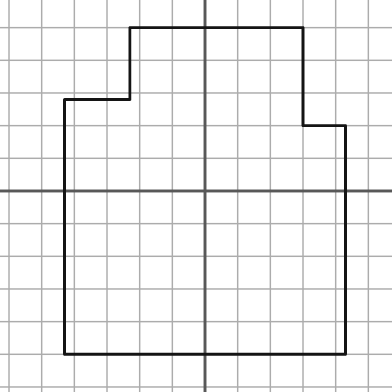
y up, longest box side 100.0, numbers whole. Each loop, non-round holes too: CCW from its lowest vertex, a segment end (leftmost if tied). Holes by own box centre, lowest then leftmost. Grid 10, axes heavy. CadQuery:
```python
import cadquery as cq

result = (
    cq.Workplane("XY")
    .moveTo(-43.0, -50.0)
    .lineTo(43.0, -50.0)
    .lineTo(43.0, 20.0)
    .lineTo(30.0, 20.0)
    .lineTo(30.0, 50.0)
    .lineTo(-23.0, 50.0)
    .lineTo(-23.0, 28.0)
    .lineTo(-43.0, 28.0)
    .close()
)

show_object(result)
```